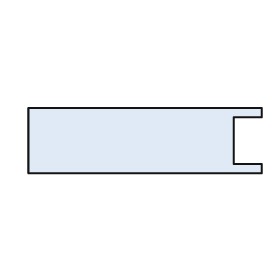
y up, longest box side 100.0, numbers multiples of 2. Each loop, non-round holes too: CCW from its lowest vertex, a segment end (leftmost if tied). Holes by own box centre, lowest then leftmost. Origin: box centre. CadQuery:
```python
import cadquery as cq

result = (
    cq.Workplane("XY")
    .moveTo(-50.0, -14.0)
    .lineTo(50.0, -14.0)
    .lineTo(50.0, -10.0)
    .lineTo(38.0, -10.0)
    .lineTo(38.0, 10.0)
    .lineTo(50.0, 10.0)
    .lineTo(50.0, 14.0)
    .lineTo(-50.0, 14.0)
    .close()
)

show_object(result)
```